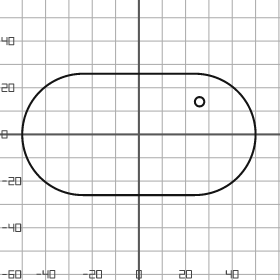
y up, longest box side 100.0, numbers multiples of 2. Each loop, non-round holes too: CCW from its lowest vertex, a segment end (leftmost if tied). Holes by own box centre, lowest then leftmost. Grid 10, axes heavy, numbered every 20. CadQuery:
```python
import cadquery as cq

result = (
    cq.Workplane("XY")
    .moveTo(-24.0, -26.0)
    .lineTo(24.0, -26.0)
    .threePointArc((50.0, 0.0), (24.0, 26.0))
    .lineTo(-24.0, 26.0)
    .threePointArc((-50.0, 0.0), (-24.0, -26.0))
    .close()
    .moveTo(26.0, 14.0)
    .circle(2.0)
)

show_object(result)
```